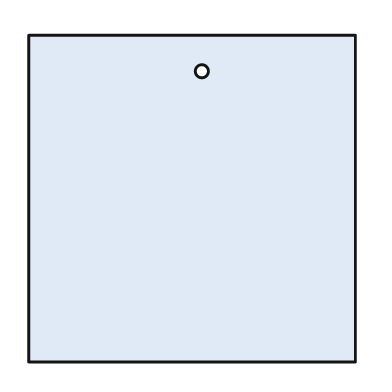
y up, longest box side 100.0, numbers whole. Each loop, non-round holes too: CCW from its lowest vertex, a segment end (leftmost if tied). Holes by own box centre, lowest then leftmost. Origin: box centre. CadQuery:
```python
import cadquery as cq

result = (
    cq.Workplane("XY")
    .moveTo(-50.0, -50.0)
    .lineTo(50.0, -50.0)
    .lineTo(50.0, 50.0)
    .lineTo(-50.0, 50.0)
    .close()
    .moveTo(3.0, 39.0)
    .circle(2.0)
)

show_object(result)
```